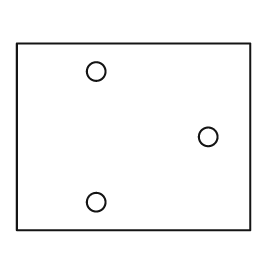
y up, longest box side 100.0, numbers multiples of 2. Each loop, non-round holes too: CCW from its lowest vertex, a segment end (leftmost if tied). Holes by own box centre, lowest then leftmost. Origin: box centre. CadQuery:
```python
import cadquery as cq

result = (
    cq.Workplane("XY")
    .moveTo(-50.0, -40.0)
    .lineTo(50.0, -40.0)
    .lineTo(50.0, 40.0)
    .lineTo(-50.0, 40.0)
    .close()
    .moveTo(-16.0, -28.0)
    .circle(4.0)
    .moveTo(32.0, 0.0)
    .circle(4.0)
    .moveTo(-16.0, 28.0)
    .circle(4.0)
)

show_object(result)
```